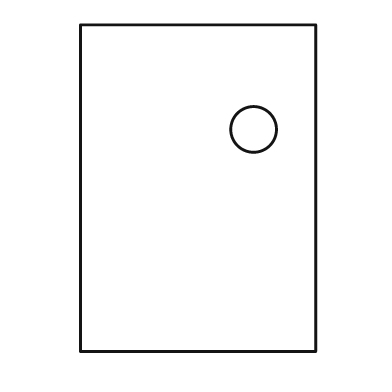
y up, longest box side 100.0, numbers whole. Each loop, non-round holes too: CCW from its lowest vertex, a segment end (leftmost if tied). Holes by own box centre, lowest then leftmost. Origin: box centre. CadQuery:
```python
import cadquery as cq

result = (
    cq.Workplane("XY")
    .moveTo(-36.0, -50.0)
    .lineTo(36.0, -50.0)
    .lineTo(36.0, 50.0)
    .lineTo(-36.0, 50.0)
    .close()
    .moveTo(17.0, 18.0)
    .circle(7.0)
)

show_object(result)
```